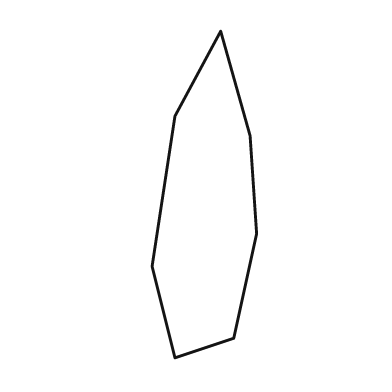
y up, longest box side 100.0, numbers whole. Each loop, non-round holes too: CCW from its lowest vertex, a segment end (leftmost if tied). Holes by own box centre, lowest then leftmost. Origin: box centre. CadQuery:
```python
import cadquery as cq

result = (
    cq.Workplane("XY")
    .moveTo(-9.0, -50.0)
    .lineTo(9.0, -44.0)
    .lineTo(16.0, -12.0)
    .lineTo(14.0, 18.0)
    .lineTo(5.0, 50.0)
    .lineTo(-9.0, 24.0)
    .lineTo(-16.0, -22.0)
    .close()
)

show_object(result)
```